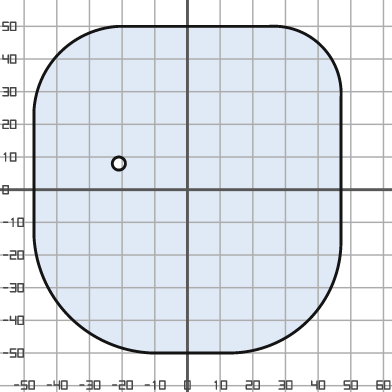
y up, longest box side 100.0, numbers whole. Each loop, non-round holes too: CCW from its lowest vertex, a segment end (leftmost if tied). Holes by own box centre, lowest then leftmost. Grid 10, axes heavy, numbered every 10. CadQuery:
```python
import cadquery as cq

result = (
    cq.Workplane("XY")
    .moveTo(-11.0, -50.0)
    .lineTo(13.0, -50.0)
    .threePointArc((37.0, -40.0), (47.0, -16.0))
    .lineTo(47.0, 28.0)
    .threePointArc((41.0, 44.0), (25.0, 50.0))
    .lineTo(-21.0, 50.0)
    .threePointArc((-39.0, 42.0), (-47.0, 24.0))
    .lineTo(-47.0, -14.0)
    .threePointArc((-36.0, -39.0), (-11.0, -50.0))
    .close()
    .moveTo(-21.0, 8.0)
    .circle(2.0)
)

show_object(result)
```